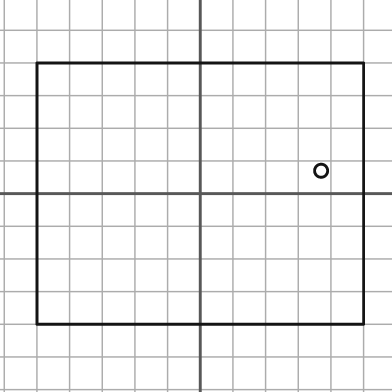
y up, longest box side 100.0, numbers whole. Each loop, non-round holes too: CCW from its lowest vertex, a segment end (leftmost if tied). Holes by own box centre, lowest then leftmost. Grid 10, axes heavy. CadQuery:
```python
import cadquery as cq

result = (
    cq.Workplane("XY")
    .moveTo(-50.0, -40.0)
    .lineTo(50.0, -40.0)
    .lineTo(50.0, 40.0)
    .lineTo(-50.0, 40.0)
    .close()
    .moveTo(37.0, 7.0)
    .circle(2.0)
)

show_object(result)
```